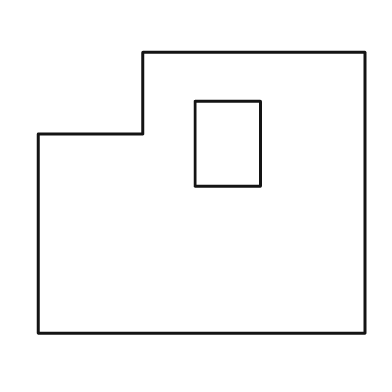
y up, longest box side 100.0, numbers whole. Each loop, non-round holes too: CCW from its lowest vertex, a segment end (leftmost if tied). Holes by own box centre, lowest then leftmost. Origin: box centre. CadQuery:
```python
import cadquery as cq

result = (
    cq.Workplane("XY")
    .moveTo(-50.0, -43.0)
    .lineTo(50.0, -43.0)
    .lineTo(50.0, 43.0)
    .lineTo(-18.0, 43.0)
    .lineTo(-18.0, 18.0)
    .lineTo(-50.0, 18.0)
    .close()
    .moveTo(-2.0, 2.0)
    .lineTo(18.0, 2.0)
    .lineTo(18.0, 28.0)
    .lineTo(-2.0, 28.0)
    .close()
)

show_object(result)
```